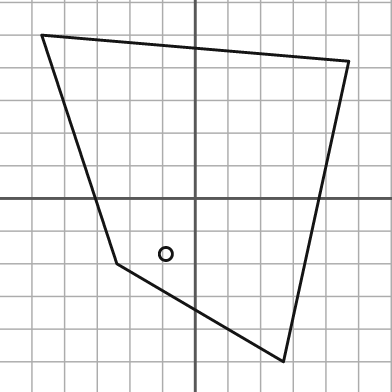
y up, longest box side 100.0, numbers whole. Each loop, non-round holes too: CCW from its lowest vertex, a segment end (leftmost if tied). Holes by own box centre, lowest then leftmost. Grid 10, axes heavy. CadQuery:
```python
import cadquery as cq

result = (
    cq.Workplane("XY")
    .moveTo(27.0, -50.0)
    .lineTo(47.0, 42.0)
    .lineTo(-47.0, 50.0)
    .lineTo(-24.0, -20.0)
    .close()
    .moveTo(-9.0, -17.0)
    .circle(2.0)
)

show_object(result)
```